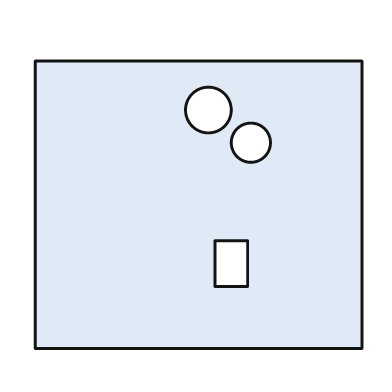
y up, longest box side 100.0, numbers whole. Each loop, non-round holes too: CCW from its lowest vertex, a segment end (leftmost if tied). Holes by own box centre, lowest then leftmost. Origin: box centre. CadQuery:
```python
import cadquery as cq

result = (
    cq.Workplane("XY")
    .moveTo(-50.0, -44.0)
    .lineTo(50.0, -44.0)
    .lineTo(50.0, 44.0)
    .lineTo(-50.0, 44.0)
    .close()
    .moveTo(5.0, -25.0)
    .lineTo(15.0, -25.0)
    .lineTo(15.0, -11.0)
    .lineTo(5.0, -11.0)
    .close()
    .moveTo(16.0, 19.0)
    .circle(6.0)
    .moveTo(3.0, 29.0)
    .circle(7.0)
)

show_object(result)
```